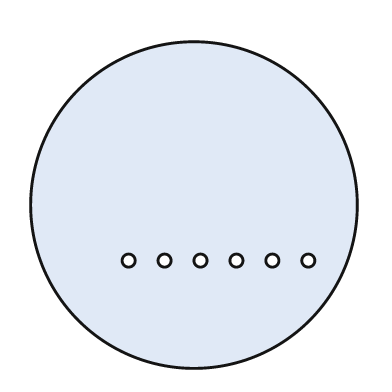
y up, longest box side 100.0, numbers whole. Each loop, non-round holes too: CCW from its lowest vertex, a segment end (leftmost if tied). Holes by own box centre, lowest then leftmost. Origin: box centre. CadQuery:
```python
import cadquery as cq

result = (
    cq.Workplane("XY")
    .moveTo(0.0, 0.0)
    .circle(50.0)
    .moveTo(-20.0, -17.0)
    .circle(2.0)
    .moveTo(-9.0, -17.0)
    .circle(2.0)
    .moveTo(2.0, -17.0)
    .circle(2.0)
    .moveTo(13.0, -17.0)
    .circle(2.0)
    .moveTo(24.0, -17.0)
    .circle(2.0)
    .moveTo(35.0, -17.0)
    .circle(2.0)
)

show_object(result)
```